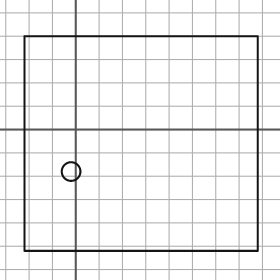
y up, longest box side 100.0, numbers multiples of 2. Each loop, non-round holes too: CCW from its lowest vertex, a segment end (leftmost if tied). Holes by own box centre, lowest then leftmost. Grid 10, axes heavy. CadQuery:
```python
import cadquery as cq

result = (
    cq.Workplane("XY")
    .moveTo(-22.0, -52.0)
    .lineTo(78.0, -52.0)
    .lineTo(78.0, 40.0)
    .lineTo(-22.0, 40.0)
    .close()
    .moveTo(-2.0, -18.0)
    .circle(4.0)
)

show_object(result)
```